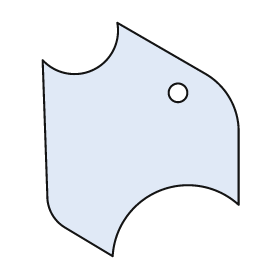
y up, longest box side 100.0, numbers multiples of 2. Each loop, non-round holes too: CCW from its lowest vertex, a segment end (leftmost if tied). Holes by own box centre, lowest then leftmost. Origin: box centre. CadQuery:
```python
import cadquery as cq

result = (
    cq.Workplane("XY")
    .moveTo(-12.0, -50.0)
    .threePointArc((8.0, -22.0), (42.0, -28.0))
    .lineTo(42.0, 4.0)
    .threePointArc((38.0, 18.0), (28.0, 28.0))
    .lineTo(-10.0, 50.0)
    .threePointArc((-20.0, 30.0), (-42.0, 34.0))
    .lineTo(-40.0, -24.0)
    .threePointArc((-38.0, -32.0), (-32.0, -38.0))
    .close()
    .moveTo(16.0, 20.0)
    .circle(4.0)
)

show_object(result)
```